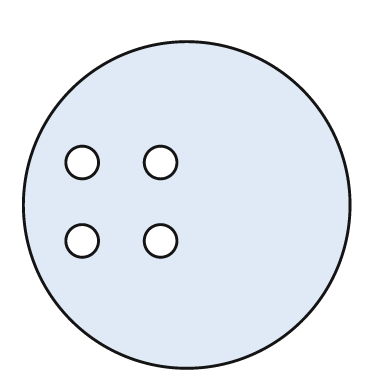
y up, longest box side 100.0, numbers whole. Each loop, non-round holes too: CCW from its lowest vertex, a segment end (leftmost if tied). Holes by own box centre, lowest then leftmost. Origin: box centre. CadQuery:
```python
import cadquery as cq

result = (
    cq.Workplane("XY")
    .moveTo(0.0, 0.0)
    .circle(50.0)
    .moveTo(-32.0, -11.0)
    .circle(5.0)
    .moveTo(-8.0, -11.0)
    .circle(5.0)
    .moveTo(-32.0, 13.0)
    .circle(5.0)
    .moveTo(-8.0, 13.0)
    .circle(5.0)
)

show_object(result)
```